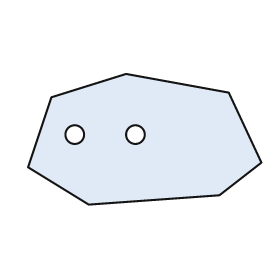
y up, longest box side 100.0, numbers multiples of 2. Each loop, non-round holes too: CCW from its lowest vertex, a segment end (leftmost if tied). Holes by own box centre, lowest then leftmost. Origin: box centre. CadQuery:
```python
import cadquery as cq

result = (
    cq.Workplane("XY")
    .moveTo(-24.0, -28.0)
    .lineTo(32.0, -24.0)
    .lineTo(50.0, -10.0)
    .lineTo(36.0, 20.0)
    .lineTo(-8.0, 28.0)
    .lineTo(-40.0, 18.0)
    .lineTo(-50.0, -12.0)
    .close()
    .moveTo(-30.0, 2.0)
    .circle(4.0)
    .moveTo(-4.0, 2.0)
    .circle(4.0)
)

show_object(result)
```